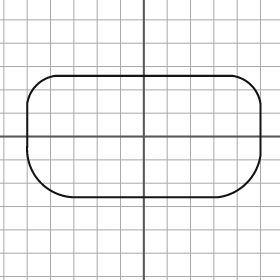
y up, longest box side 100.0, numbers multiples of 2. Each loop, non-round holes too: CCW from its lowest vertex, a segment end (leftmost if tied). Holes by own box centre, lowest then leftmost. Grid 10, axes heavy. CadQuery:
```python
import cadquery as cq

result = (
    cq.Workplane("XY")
    .moveTo(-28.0, -26.0)
    .lineTo(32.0, -26.0)
    .threePointArc((44.0, -20.0), (50.0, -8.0))
    .lineTo(50.0, 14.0)
    .threePointArc((46.0, 22.0), (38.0, 26.0))
    .lineTo(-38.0, 26.0)
    .threePointArc((-46.0, 22.0), (-50.0, 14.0))
    .lineTo(-50.0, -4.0)
    .threePointArc((-44.0, -20.0), (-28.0, -26.0))
    .close()
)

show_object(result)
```